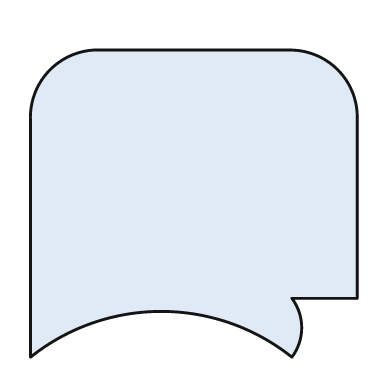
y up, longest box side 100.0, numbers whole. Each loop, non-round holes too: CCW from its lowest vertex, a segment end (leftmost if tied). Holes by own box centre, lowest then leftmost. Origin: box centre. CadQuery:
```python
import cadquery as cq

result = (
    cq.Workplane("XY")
    .moveTo(-50.0, -47.0)
    .threePointArc((-10.0, -33.0), (30.0, -47.0))
    .threePointArc((33.0, -38.0), (30.0, -29.0))
    .lineTo(50.0, -29.0)
    .lineTo(50.0, 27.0)
    .threePointArc((44.0, 41.0), (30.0, 47.0))
    .lineTo(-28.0, 47.0)
    .threePointArc((-44.0, 41.0), (-50.0, 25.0))
    .close()
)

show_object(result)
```